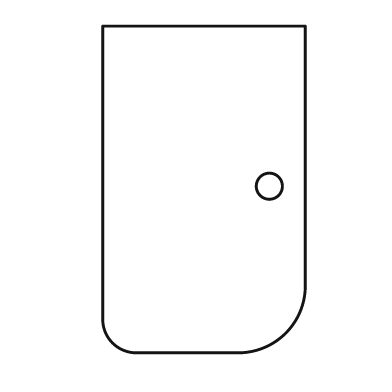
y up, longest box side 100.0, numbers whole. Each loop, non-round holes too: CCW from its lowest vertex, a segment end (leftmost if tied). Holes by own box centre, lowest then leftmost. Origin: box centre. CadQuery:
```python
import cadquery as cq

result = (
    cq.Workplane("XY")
    .moveTo(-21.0, -50.0)
    .lineTo(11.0, -50.0)
    .threePointArc((25.0, -44.0), (31.0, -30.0))
    .lineTo(31.0, 50.0)
    .lineTo(-31.0, 50.0)
    .lineTo(-31.0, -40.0)
    .threePointArc((-28.0, -47.0), (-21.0, -50.0))
    .close()
    .moveTo(20.0, 1.0)
    .circle(4.0)
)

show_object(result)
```